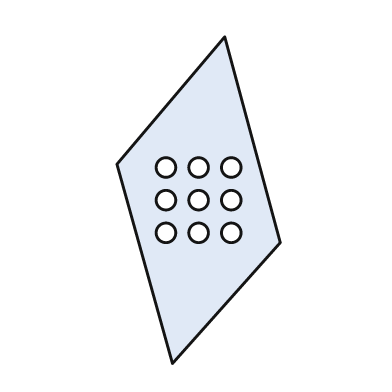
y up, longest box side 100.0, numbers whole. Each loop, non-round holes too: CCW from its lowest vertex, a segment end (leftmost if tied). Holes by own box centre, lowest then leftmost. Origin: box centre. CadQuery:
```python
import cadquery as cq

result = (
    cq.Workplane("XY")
    .moveTo(-8.0, -50.0)
    .lineTo(25.0, -13.0)
    .lineTo(8.0, 50.0)
    .lineTo(-25.0, 11.0)
    .close()
    .moveTo(-10.0, -10.0)
    .circle(3.0)
    .moveTo(0.0, -10.0)
    .circle(3.0)
    .moveTo(10.0, -10.0)
    .circle(3.0)
    .moveTo(-10.0, 0.0)
    .circle(3.0)
    .moveTo(0.0, 0.0)
    .circle(3.0)
    .moveTo(10.0, 0.0)
    .circle(3.0)
    .moveTo(-10.0, 10.0)
    .circle(3.0)
    .moveTo(0.0, 10.0)
    .circle(3.0)
    .moveTo(10.0, 10.0)
    .circle(3.0)
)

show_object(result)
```